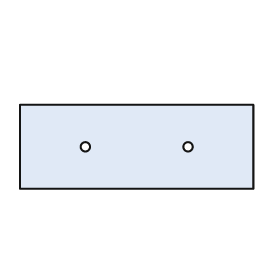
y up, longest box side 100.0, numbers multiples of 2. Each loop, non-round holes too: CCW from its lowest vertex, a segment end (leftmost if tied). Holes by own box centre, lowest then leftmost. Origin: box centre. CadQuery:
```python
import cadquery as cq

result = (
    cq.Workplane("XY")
    .moveTo(-50.0, -18.0)
    .lineTo(50.0, -18.0)
    .lineTo(50.0, 18.0)
    .lineTo(-50.0, 18.0)
    .close()
    .moveTo(-22.0, 0.0)
    .circle(2.0)
    .moveTo(22.0, 0.0)
    .circle(2.0)
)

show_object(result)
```